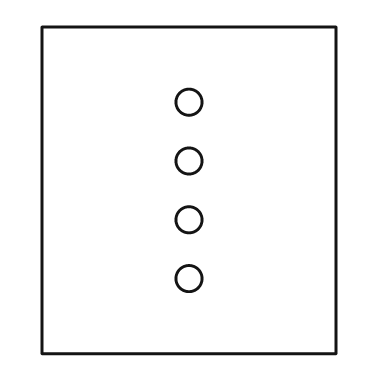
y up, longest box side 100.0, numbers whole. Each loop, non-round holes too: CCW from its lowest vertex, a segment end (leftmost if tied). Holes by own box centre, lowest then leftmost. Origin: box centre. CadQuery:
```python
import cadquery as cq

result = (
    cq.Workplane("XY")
    .moveTo(-45.0, -50.0)
    .lineTo(45.0, -50.0)
    .lineTo(45.0, 50.0)
    .lineTo(-45.0, 50.0)
    .close()
    .moveTo(0.0, -27.0)
    .circle(4.0)
    .moveTo(0.0, -9.0)
    .circle(4.0)
    .moveTo(0.0, 9.0)
    .circle(4.0)
    .moveTo(0.0, 27.0)
    .circle(4.0)
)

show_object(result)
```